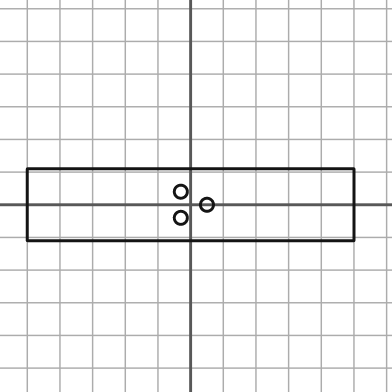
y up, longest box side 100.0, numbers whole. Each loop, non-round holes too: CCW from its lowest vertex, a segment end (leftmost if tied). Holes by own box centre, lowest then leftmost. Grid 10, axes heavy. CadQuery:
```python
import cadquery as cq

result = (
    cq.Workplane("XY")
    .moveTo(-50.0, -11.0)
    .lineTo(50.0, -11.0)
    .lineTo(50.0, 11.0)
    .lineTo(-50.0, 11.0)
    .close()
    .moveTo(-3.0, -4.0)
    .circle(2.0)
    .moveTo(5.0, 0.0)
    .circle(2.0)
    .moveTo(-3.0, 4.0)
    .circle(2.0)
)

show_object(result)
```